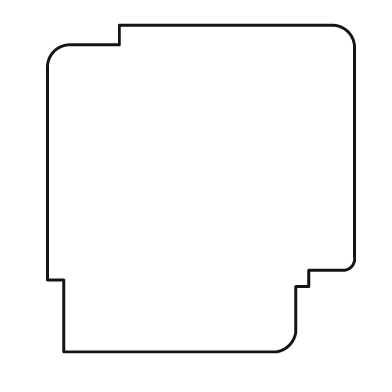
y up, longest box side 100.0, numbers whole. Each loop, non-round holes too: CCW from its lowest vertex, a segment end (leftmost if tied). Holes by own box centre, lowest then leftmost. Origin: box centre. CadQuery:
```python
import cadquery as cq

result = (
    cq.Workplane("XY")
    .moveTo(-42.0, -50.0)
    .lineTo(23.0, -50.0)
    .threePointArc((27.0, -48.0), (29.0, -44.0))
    .lineTo(29.0, -30.0)
    .lineTo(33.0, -30.0)
    .lineTo(33.0, -25.0)
    .lineTo(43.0, -25.0)
    .threePointArc((46.0, -24.0), (47.0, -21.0))
    .lineTo(47.0, 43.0)
    .threePointArc((45.0, 48.0), (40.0, 50.0))
    .lineTo(-25.0, 50.0)
    .lineTo(-25.0, 44.0)
    .lineTo(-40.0, 44.0)
    .threePointArc((-45.0, 42.0), (-47.0, 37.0))
    .lineTo(-47.0, -28.0)
    .lineTo(-42.0, -28.0)
    .close()
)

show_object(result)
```